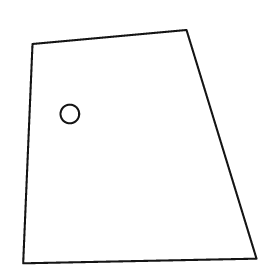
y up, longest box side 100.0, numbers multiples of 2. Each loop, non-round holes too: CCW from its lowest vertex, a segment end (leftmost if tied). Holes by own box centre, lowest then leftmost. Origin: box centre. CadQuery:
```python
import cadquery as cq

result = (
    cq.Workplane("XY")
    .moveTo(-50.0, -50.0)
    .lineTo(50.0, -48.0)
    .lineTo(20.0, 50.0)
    .lineTo(-46.0, 44.0)
    .close()
    .moveTo(-30.0, 14.0)
    .circle(4.0)
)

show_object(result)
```